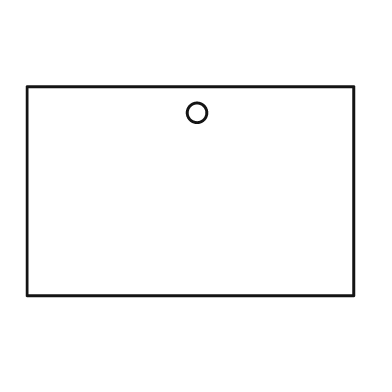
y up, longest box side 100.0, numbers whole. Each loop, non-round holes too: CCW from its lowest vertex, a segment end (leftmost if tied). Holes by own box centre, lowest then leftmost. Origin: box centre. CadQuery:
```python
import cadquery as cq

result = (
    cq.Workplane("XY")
    .moveTo(-50.0, -32.0)
    .lineTo(50.0, -32.0)
    .lineTo(50.0, 32.0)
    .lineTo(-50.0, 32.0)
    .close()
    .moveTo(2.0, 24.0)
    .circle(3.0)
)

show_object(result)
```